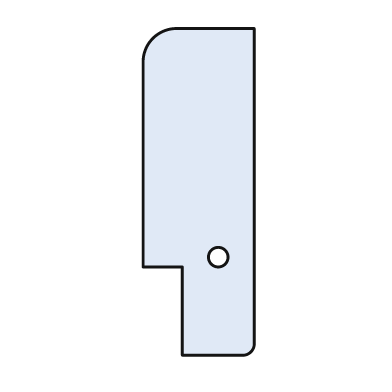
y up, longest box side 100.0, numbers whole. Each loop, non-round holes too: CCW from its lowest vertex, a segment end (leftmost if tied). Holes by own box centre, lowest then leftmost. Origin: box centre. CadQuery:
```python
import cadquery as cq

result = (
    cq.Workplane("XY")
    .moveTo(-5.0, -50.0)
    .lineTo(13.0, -50.0)
    .threePointArc((16.0, -49.0), (17.0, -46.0))
    .lineTo(17.0, 50.0)
    .lineTo(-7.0, 50.0)
    .threePointArc((-14.0, 47.0), (-17.0, 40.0))
    .lineTo(-17.0, -23.0)
    .lineTo(-5.0, -23.0)
    .close()
    .moveTo(6.0, -20.0)
    .circle(3.0)
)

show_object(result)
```